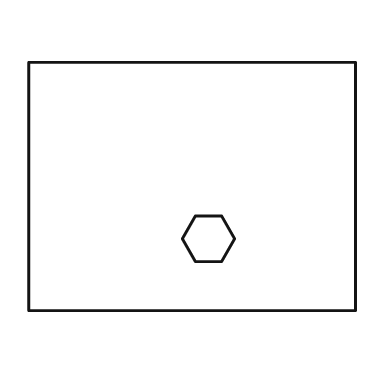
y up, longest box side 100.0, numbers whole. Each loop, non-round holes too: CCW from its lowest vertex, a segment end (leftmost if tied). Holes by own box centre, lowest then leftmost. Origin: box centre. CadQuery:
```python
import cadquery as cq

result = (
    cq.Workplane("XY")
    .moveTo(-50.0, -38.0)
    .lineTo(50.0, -38.0)
    .lineTo(50.0, 38.0)
    .lineTo(-50.0, 38.0)
    .close()
    .moveTo(1.0, -23.0)
    .lineTo(9.0, -23.0)
    .lineTo(13.0, -16.0)
    .lineTo(9.0, -9.0)
    .lineTo(1.0, -9.0)
    .lineTo(-3.0, -16.0)
    .close()
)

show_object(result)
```